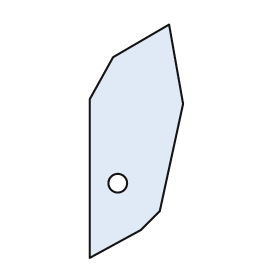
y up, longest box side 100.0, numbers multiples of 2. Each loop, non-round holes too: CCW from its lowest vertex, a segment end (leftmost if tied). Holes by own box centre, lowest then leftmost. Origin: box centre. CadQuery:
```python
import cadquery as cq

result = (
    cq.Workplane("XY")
    .moveTo(-20.0, -50.0)
    .lineTo(2.0, -38.0)
    .lineTo(10.0, -30.0)
    .lineTo(20.0, 16.0)
    .lineTo(14.0, 50.0)
    .lineTo(-10.0, 36.0)
    .lineTo(-20.0, 18.0)
    .close()
    .moveTo(-8.0, -18.0)
    .circle(4.0)
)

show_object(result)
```